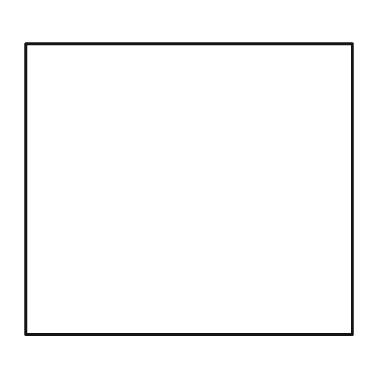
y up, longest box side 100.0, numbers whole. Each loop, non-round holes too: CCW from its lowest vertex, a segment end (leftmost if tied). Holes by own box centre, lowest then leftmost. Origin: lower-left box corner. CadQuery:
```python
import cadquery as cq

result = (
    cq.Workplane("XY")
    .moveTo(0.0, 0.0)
    .lineTo(100.0, 0.0)
    .lineTo(100.0, 89.0)
    .lineTo(0.0, 89.0)
    .close()
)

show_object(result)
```